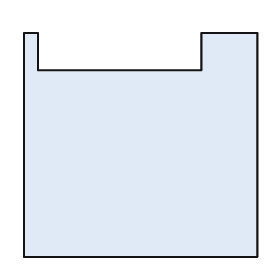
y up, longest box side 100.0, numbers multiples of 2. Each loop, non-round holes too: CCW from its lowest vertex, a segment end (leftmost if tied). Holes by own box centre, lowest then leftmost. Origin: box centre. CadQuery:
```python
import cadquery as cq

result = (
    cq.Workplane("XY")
    .moveTo(-50.0, -48.0)
    .lineTo(50.0, -48.0)
    .lineTo(50.0, 48.0)
    .lineTo(26.0, 48.0)
    .lineTo(26.0, 32.0)
    .lineTo(-44.0, 32.0)
    .lineTo(-44.0, 48.0)
    .lineTo(-50.0, 48.0)
    .close()
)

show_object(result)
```